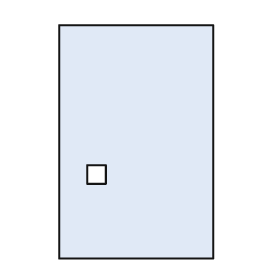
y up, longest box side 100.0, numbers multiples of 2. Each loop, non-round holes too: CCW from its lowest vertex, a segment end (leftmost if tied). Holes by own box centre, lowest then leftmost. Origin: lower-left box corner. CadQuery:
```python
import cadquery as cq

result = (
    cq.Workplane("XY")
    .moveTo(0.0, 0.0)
    .lineTo(66.0, 0.0)
    .lineTo(66.0, 100.0)
    .lineTo(0.0, 100.0)
    .close()
    .moveTo(12.0, 32.0)
    .lineTo(20.0, 32.0)
    .lineTo(20.0, 40.0)
    .lineTo(12.0, 40.0)
    .close()
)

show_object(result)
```